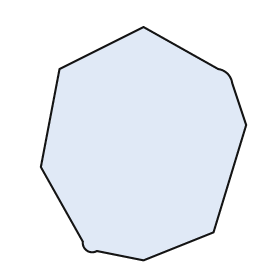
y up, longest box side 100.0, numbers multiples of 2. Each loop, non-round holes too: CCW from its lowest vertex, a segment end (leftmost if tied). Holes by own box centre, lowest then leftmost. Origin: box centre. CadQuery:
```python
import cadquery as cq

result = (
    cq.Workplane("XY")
    .moveTo(0.0, -50.0)
    .lineTo(30.0, -38.0)
    .lineTo(44.0, 8.0)
    .lineTo(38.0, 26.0)
    .threePointArc((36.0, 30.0), (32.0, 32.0))
    .lineTo(0.0, 50.0)
    .lineTo(-36.0, 32.0)
    .lineTo(-44.0, -10.0)
    .lineTo(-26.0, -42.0)
    .threePointArc((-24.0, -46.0), (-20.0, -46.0))
    .close()
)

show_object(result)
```